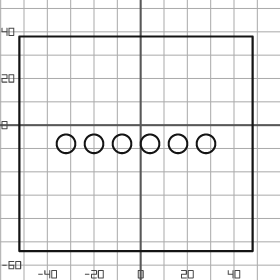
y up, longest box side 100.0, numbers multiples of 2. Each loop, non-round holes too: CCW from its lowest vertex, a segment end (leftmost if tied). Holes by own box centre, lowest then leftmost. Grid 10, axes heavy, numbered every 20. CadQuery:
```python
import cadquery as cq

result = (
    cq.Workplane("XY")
    .moveTo(-52.0, -54.0)
    .lineTo(48.0, -54.0)
    .lineTo(48.0, 38.0)
    .lineTo(-52.0, 38.0)
    .close()
    .moveTo(-32.0, -8.0)
    .circle(4.0)
    .moveTo(-20.0, -8.0)
    .circle(4.0)
    .moveTo(-8.0, -8.0)
    .circle(4.0)
    .moveTo(4.0, -8.0)
    .circle(4.0)
    .moveTo(16.0, -8.0)
    .circle(4.0)
    .moveTo(28.0, -8.0)
    .circle(4.0)
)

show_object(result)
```